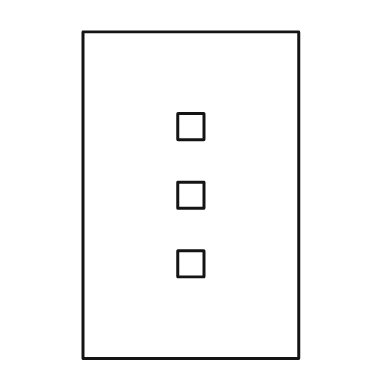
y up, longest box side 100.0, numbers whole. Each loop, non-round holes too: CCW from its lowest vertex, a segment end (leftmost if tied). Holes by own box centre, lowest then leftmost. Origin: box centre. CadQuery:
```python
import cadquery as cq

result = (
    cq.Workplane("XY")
    .moveTo(-33.0, -50.0)
    .lineTo(33.0, -50.0)
    .lineTo(33.0, 50.0)
    .lineTo(-33.0, 50.0)
    .close()
    .moveTo(-4.0, -25.0)
    .lineTo(4.0, -25.0)
    .lineTo(4.0, -17.0)
    .lineTo(-4.0, -17.0)
    .close()
    .moveTo(-4.0, -4.0)
    .lineTo(4.0, -4.0)
    .lineTo(4.0, 4.0)
    .lineTo(-4.0, 4.0)
    .close()
    .moveTo(-4.0, 17.0)
    .lineTo(4.0, 17.0)
    .lineTo(4.0, 25.0)
    .lineTo(-4.0, 25.0)
    .close()
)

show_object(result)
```